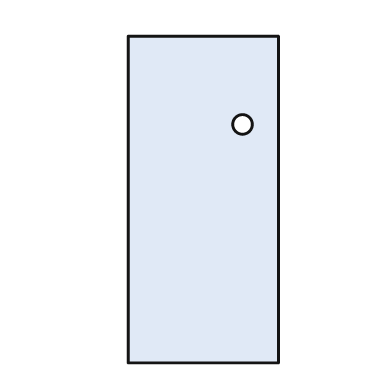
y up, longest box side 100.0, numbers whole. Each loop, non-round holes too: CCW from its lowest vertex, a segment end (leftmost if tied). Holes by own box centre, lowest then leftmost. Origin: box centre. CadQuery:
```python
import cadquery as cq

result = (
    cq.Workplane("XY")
    .moveTo(-23.0, -50.0)
    .lineTo(23.0, -50.0)
    .lineTo(23.0, 50.0)
    .lineTo(-23.0, 50.0)
    .close()
    .moveTo(12.0, 23.0)
    .circle(3.0)
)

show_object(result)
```